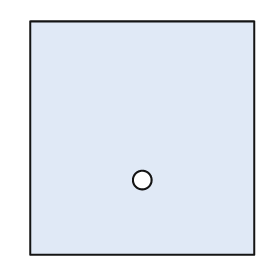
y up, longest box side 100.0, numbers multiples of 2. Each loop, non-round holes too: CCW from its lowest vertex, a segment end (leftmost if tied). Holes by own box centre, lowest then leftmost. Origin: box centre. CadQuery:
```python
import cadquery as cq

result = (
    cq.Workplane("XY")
    .moveTo(-48.0, -50.0)
    .lineTo(48.0, -50.0)
    .lineTo(48.0, 50.0)
    .lineTo(-48.0, 50.0)
    .close()
    .moveTo(0.0, -18.0)
    .circle(4.0)
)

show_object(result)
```